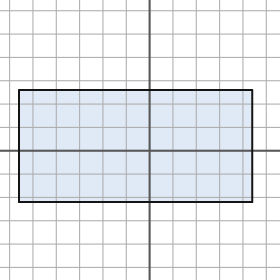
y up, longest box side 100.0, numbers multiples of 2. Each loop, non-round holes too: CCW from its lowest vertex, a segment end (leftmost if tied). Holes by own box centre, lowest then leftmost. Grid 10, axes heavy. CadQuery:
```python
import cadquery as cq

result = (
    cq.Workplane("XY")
    .moveTo(-56.0, -22.0)
    .lineTo(44.0, -22.0)
    .lineTo(44.0, 26.0)
    .lineTo(-56.0, 26.0)
    .close()
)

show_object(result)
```